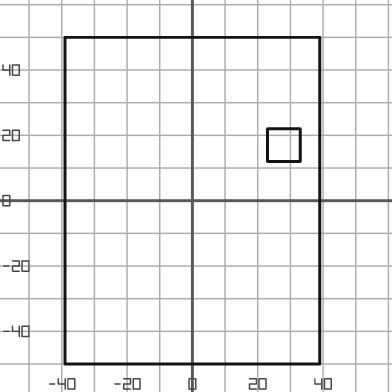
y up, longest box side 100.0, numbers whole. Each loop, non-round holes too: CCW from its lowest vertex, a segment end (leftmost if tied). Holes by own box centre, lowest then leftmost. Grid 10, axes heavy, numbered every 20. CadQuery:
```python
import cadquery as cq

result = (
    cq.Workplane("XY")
    .moveTo(-39.0, -50.0)
    .lineTo(39.0, -50.0)
    .lineTo(39.0, 50.0)
    .lineTo(-39.0, 50.0)
    .close()
    .moveTo(23.0, 12.0)
    .lineTo(33.0, 12.0)
    .lineTo(33.0, 22.0)
    .lineTo(23.0, 22.0)
    .close()
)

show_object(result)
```